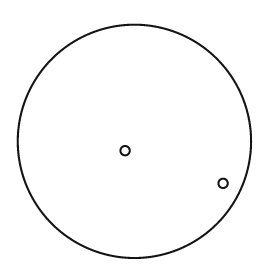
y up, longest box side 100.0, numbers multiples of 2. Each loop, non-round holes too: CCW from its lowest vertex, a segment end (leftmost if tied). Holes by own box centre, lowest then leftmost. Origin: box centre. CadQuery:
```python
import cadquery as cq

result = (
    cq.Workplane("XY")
    .moveTo(0.0, 0.0)
    .circle(50.0)
    .moveTo(38.0, -18.0)
    .circle(2.0)
    .moveTo(-4.0, -4.0)
    .circle(2.0)
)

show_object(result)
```